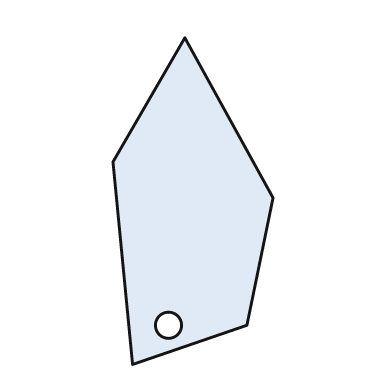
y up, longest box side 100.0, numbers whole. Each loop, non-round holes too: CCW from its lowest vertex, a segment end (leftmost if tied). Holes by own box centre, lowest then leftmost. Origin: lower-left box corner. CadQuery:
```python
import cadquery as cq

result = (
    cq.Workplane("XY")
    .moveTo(6.0, 0.0)
    .lineTo(41.0, 12.0)
    .lineTo(49.0, 51.0)
    .lineTo(22.0, 100.0)
    .lineTo(0.0, 62.0)
    .close()
    .moveTo(17.0, 12.0)
    .circle(4.0)
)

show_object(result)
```